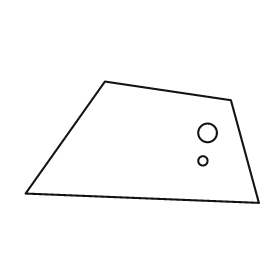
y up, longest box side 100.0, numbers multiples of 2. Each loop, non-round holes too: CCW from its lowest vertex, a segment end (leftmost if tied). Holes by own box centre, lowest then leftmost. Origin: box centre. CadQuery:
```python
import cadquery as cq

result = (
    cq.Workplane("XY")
    .moveTo(50.0, -26.0)
    .lineTo(38.0, 18.0)
    .lineTo(-16.0, 26.0)
    .lineTo(-50.0, -22.0)
    .close()
    .moveTo(26.0, -8.0)
    .circle(2.0)
    .moveTo(28.0, 4.0)
    .circle(4.0)
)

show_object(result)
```